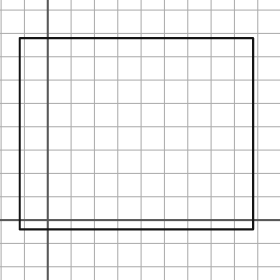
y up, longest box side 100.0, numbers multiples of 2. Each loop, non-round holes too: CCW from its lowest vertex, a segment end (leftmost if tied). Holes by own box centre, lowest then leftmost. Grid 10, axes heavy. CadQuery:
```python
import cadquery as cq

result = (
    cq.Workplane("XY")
    .moveTo(-12.0, -4.0)
    .lineTo(88.0, -4.0)
    .lineTo(88.0, 78.0)
    .lineTo(-12.0, 78.0)
    .close()
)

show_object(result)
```